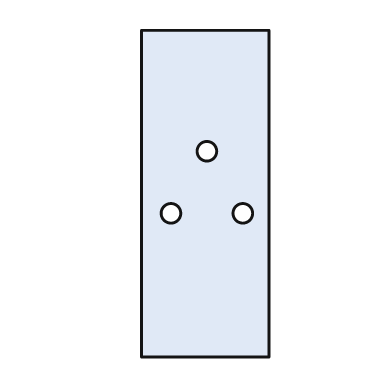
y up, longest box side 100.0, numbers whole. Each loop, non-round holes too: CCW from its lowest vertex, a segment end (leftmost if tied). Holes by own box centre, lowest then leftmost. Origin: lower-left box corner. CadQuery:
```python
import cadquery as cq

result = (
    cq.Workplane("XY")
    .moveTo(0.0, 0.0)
    .lineTo(39.0, 0.0)
    .lineTo(39.0, 100.0)
    .lineTo(0.0, 100.0)
    .close()
    .moveTo(9.0, 44.0)
    .circle(3.0)
    .moveTo(31.0, 44.0)
    .circle(3.0)
    .moveTo(20.0, 63.0)
    .circle(3.0)
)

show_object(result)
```